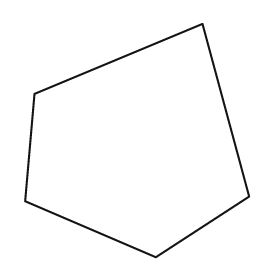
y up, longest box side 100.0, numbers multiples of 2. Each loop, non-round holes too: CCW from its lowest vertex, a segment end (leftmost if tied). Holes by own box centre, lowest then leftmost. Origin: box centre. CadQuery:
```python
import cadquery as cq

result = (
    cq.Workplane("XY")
    .moveTo(8.0, -50.0)
    .lineTo(48.0, -24.0)
    .lineTo(28.0, 50.0)
    .lineTo(-44.0, 20.0)
    .lineTo(-48.0, -26.0)
    .close()
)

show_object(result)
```